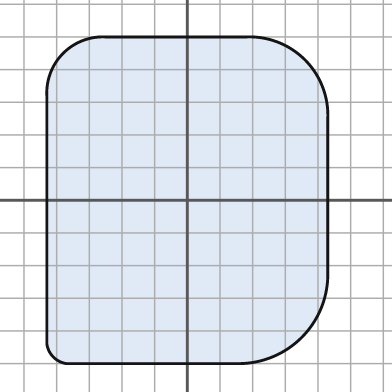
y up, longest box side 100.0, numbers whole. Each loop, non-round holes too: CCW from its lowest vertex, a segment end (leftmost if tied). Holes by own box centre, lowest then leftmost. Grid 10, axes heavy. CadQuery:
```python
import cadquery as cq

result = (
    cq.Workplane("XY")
    .moveTo(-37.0, -50.0)
    .lineTo(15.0, -50.0)
    .threePointArc((35.0, -42.0), (43.0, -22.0))
    .lineTo(43.0, 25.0)
    .threePointArc((36.0, 43.0), (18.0, 50.0))
    .lineTo(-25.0, 50.0)
    .threePointArc((-38.0, 45.0), (-43.0, 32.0))
    .lineTo(-43.0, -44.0)
    .threePointArc((-41.0, -48.0), (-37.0, -50.0))
    .close()
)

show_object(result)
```